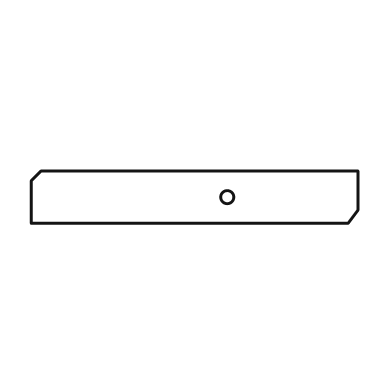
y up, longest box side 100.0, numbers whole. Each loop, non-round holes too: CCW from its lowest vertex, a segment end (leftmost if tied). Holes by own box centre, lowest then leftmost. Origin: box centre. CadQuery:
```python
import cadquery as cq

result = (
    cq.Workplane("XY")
    .moveTo(-50.0, -8.0)
    .lineTo(47.0, -8.0)
    .lineTo(50.0, -4.0)
    .lineTo(50.0, 8.0)
    .lineTo(-47.0, 8.0)
    .lineTo(-50.0, 5.0)
    .close()
    .moveTo(10.0, 0.0)
    .circle(2.0)
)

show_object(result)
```